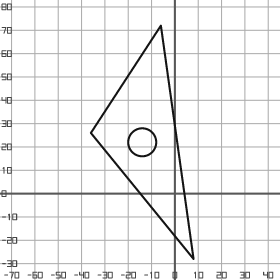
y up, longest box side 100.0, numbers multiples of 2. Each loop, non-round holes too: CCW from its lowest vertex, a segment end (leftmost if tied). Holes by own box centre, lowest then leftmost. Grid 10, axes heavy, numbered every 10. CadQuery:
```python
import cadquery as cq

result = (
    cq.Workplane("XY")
    .moveTo(8.0, -28.0)
    .lineTo(-6.0, 72.0)
    .lineTo(-36.0, 26.0)
    .close()
    .moveTo(-14.0, 22.0)
    .circle(6.0)
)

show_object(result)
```